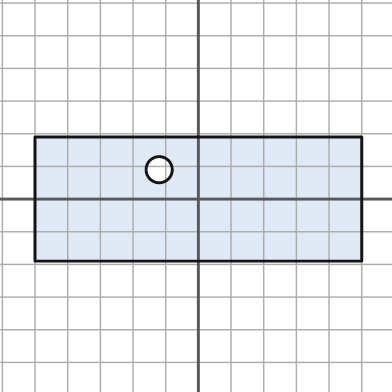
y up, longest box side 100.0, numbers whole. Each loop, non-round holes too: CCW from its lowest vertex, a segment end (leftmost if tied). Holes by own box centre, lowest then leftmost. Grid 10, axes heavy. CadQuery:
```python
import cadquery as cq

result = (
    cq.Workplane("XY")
    .moveTo(-50.0, -19.0)
    .lineTo(50.0, -19.0)
    .lineTo(50.0, 19.0)
    .lineTo(-50.0, 19.0)
    .close()
    .moveTo(-12.0, 9.0)
    .circle(4.0)
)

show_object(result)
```